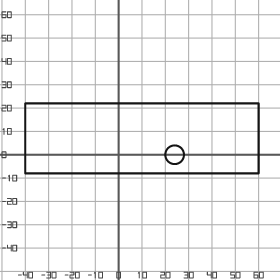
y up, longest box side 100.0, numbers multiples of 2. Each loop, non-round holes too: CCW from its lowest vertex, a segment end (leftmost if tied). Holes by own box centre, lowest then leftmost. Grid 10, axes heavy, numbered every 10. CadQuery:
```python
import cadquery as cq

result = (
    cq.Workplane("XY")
    .moveTo(-40.0, -8.0)
    .lineTo(60.0, -8.0)
    .lineTo(60.0, 22.0)
    .lineTo(-40.0, 22.0)
    .close()
    .moveTo(24.0, 0.0)
    .circle(4.0)
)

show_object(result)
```